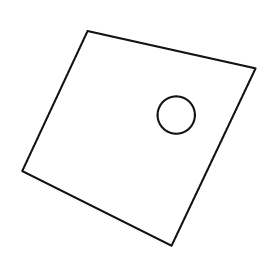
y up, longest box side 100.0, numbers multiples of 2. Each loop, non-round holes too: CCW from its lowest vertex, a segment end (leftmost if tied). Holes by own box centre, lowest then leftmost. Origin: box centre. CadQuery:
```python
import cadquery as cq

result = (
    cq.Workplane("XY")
    .moveTo(14.0, -46.0)
    .lineTo(50.0, 30.0)
    .lineTo(-22.0, 46.0)
    .lineTo(-50.0, -14.0)
    .close()
    .moveTo(16.0, 10.0)
    .circle(8.0)
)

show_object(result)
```